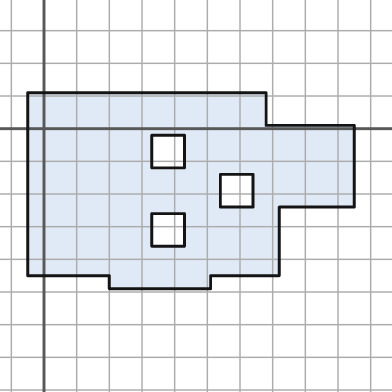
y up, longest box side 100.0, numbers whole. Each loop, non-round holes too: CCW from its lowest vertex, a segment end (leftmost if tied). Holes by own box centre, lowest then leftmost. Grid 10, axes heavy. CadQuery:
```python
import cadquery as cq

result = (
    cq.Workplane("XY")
    .moveTo(20.0, -49.0)
    .lineTo(51.0, -49.0)
    .lineTo(51.0, -45.0)
    .lineTo(72.0, -45.0)
    .lineTo(72.0, -24.0)
    .lineTo(95.0, -24.0)
    .lineTo(95.0, 1.0)
    .lineTo(68.0, 1.0)
    .lineTo(68.0, 11.0)
    .lineTo(-5.0, 11.0)
    .lineTo(-5.0, -45.0)
    .lineTo(20.0, -45.0)
    .close()
    .moveTo(33.0, -36.0)
    .lineTo(43.0, -36.0)
    .lineTo(43.0, -26.0)
    .lineTo(33.0, -26.0)
    .close()
    .moveTo(54.0, -24.0)
    .lineTo(64.0, -24.0)
    .lineTo(64.0, -14.0)
    .lineTo(54.0, -14.0)
    .close()
    .moveTo(33.0, -12.0)
    .lineTo(43.0, -12.0)
    .lineTo(43.0, -2.0)
    .lineTo(33.0, -2.0)
    .close()
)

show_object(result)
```